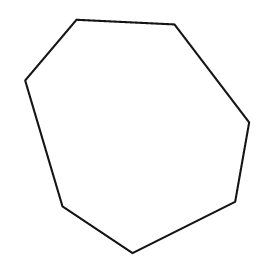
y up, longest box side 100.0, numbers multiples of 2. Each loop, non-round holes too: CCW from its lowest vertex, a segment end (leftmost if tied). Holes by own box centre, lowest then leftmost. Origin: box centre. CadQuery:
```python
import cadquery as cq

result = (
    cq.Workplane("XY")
    .moveTo(-2.0, -50.0)
    .lineTo(42.0, -28.0)
    .lineTo(48.0, 6.0)
    .lineTo(16.0, 48.0)
    .lineTo(-26.0, 50.0)
    .lineTo(-48.0, 24.0)
    .lineTo(-32.0, -30.0)
    .close()
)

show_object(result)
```